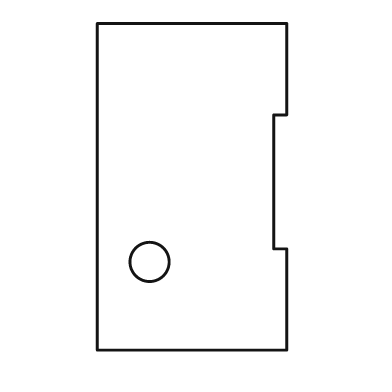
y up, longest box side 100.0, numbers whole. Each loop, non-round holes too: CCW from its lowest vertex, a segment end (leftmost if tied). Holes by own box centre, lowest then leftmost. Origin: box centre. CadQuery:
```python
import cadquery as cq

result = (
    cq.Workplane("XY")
    .moveTo(-29.0, -50.0)
    .lineTo(29.0, -50.0)
    .lineTo(29.0, -19.0)
    .lineTo(25.0, -19.0)
    .lineTo(25.0, 22.0)
    .lineTo(29.0, 22.0)
    .lineTo(29.0, 50.0)
    .lineTo(-29.0, 50.0)
    .close()
    .moveTo(-13.0, -23.0)
    .circle(6.0)
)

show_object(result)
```